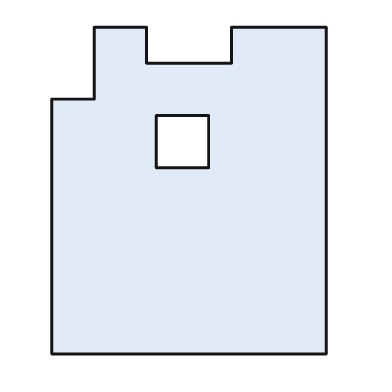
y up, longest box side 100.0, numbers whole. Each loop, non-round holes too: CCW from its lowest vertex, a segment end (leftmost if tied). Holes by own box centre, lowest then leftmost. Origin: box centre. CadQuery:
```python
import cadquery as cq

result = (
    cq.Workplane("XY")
    .moveTo(-42.0, -50.0)
    .lineTo(42.0, -50.0)
    .lineTo(42.0, 50.0)
    .lineTo(13.0, 50.0)
    .lineTo(13.0, 39.0)
    .lineTo(-13.0, 39.0)
    .lineTo(-13.0, 50.0)
    .lineTo(-29.0, 50.0)
    .lineTo(-29.0, 28.0)
    .lineTo(-42.0, 28.0)
    .close()
    .moveTo(-10.0, 7.0)
    .lineTo(6.0, 7.0)
    .lineTo(6.0, 23.0)
    .lineTo(-10.0, 23.0)
    .close()
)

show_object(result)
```